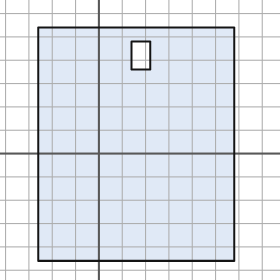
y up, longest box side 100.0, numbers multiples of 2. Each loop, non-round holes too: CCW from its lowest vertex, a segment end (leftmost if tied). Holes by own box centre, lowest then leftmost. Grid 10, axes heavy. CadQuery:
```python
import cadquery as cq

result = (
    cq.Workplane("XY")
    .moveTo(-26.0, -46.0)
    .lineTo(58.0, -46.0)
    .lineTo(58.0, 54.0)
    .lineTo(-26.0, 54.0)
    .close()
    .moveTo(14.0, 36.0)
    .lineTo(22.0, 36.0)
    .lineTo(22.0, 48.0)
    .lineTo(14.0, 48.0)
    .close()
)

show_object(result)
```